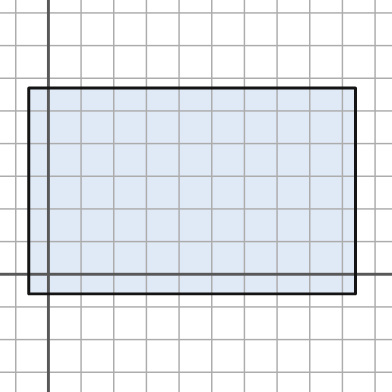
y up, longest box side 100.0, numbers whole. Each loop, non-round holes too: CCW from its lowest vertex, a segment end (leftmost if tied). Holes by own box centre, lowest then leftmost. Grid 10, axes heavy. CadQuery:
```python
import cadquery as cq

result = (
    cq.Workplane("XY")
    .moveTo(-6.0, -6.0)
    .lineTo(94.0, -6.0)
    .lineTo(94.0, 57.0)
    .lineTo(-6.0, 57.0)
    .close()
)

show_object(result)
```